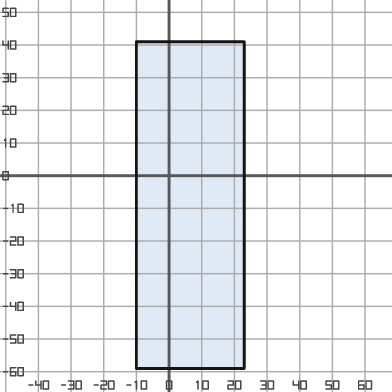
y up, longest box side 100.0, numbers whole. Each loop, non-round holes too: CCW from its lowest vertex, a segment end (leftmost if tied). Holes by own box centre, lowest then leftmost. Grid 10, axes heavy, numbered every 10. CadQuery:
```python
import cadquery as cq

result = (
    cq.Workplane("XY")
    .moveTo(-10.0, -59.0)
    .lineTo(23.0, -59.0)
    .lineTo(23.0, 41.0)
    .lineTo(-10.0, 41.0)
    .close()
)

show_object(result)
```